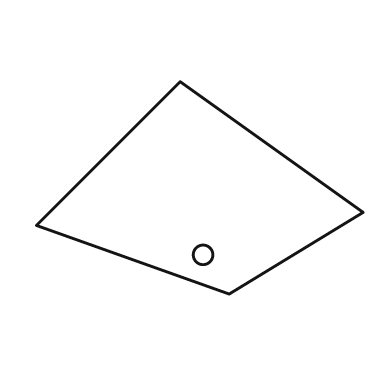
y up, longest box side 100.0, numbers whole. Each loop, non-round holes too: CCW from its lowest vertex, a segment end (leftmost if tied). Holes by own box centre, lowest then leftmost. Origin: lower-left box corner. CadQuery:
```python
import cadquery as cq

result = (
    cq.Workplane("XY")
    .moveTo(59.0, 0.0)
    .lineTo(100.0, 25.0)
    .lineTo(44.0, 65.0)
    .lineTo(0.0, 21.0)
    .close()
    .moveTo(51.0, 12.0)
    .circle(3.0)
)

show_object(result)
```